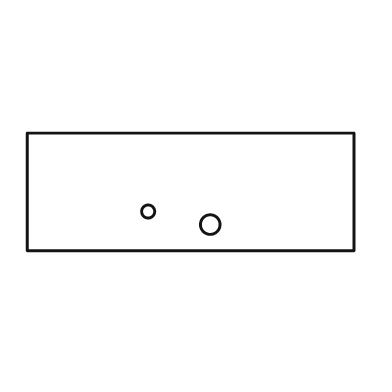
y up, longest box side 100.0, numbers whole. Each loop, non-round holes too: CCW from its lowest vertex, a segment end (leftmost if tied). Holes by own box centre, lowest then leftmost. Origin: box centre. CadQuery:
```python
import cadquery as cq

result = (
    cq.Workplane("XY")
    .moveTo(-50.0, -18.0)
    .lineTo(50.0, -18.0)
    .lineTo(50.0, 18.0)
    .lineTo(-50.0, 18.0)
    .close()
    .moveTo(6.0, -10.0)
    .circle(3.0)
    .moveTo(-13.0, -6.0)
    .circle(2.0)
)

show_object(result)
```